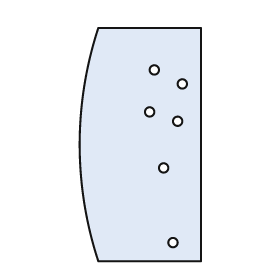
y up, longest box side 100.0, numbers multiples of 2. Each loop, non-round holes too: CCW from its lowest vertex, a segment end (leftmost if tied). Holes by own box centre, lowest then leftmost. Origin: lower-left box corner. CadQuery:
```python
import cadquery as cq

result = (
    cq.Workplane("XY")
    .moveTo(8.0, 0.0)
    .lineTo(52.0, 0.0)
    .lineTo(52.0, 100.0)
    .lineTo(8.0, 100.0)
    .threePointArc((0.0, 50.0), (8.0, 0.0))
    .close()
    .moveTo(40.0, 8.0)
    .circle(2.0)
    .moveTo(36.0, 40.0)
    .circle(2.0)
    .moveTo(42.0, 60.0)
    .circle(2.0)
    .moveTo(30.0, 64.0)
    .circle(2.0)
    .moveTo(44.0, 76.0)
    .circle(2.0)
    .moveTo(32.0, 82.0)
    .circle(2.0)
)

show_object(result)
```